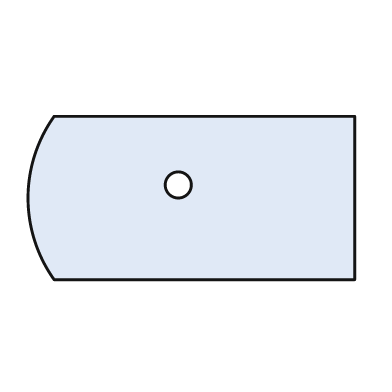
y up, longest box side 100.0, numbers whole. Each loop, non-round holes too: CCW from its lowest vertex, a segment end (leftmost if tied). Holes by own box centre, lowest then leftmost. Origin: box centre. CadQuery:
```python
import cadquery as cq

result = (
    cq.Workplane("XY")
    .moveTo(-42.0, -25.0)
    .lineTo(50.0, -25.0)
    .lineTo(50.0, 25.0)
    .lineTo(-42.0, 25.0)
    .threePointArc((-50.0, 0.0), (-42.0, -25.0))
    .close()
    .moveTo(-4.0, 4.0)
    .circle(4.0)
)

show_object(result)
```